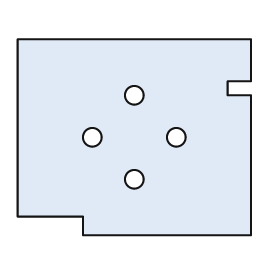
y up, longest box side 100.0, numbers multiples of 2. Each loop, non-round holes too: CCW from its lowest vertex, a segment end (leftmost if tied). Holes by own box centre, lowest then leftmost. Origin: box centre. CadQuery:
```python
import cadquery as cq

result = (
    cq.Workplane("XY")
    .moveTo(-22.0, -42.0)
    .lineTo(50.0, -42.0)
    .lineTo(50.0, 18.0)
    .lineTo(40.0, 18.0)
    .lineTo(40.0, 24.0)
    .lineTo(50.0, 24.0)
    .lineTo(50.0, 42.0)
    .lineTo(-50.0, 42.0)
    .lineTo(-50.0, -34.0)
    .lineTo(-22.0, -34.0)
    .close()
    .moveTo(0.0, -18.0)
    .circle(4.0)
    .moveTo(-18.0, 0.0)
    .circle(4.0)
    .moveTo(18.0, 0.0)
    .circle(4.0)
    .moveTo(0.0, 18.0)
    .circle(4.0)
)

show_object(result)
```